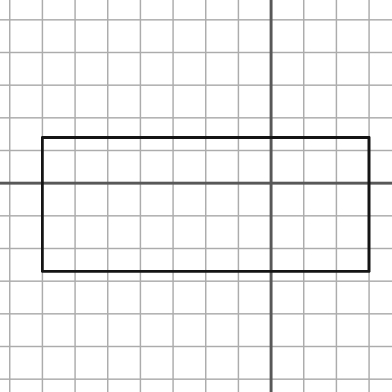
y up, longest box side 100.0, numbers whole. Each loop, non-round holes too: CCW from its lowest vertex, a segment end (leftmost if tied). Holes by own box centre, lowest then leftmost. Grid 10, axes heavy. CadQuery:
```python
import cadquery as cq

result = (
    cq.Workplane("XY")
    .moveTo(-70.0, -27.0)
    .lineTo(30.0, -27.0)
    .lineTo(30.0, 14.0)
    .lineTo(-70.0, 14.0)
    .close()
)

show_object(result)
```